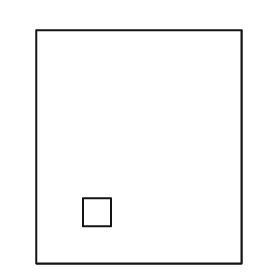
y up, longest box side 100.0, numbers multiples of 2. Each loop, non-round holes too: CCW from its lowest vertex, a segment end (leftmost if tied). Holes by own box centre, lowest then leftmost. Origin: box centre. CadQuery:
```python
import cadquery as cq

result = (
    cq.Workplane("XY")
    .moveTo(-44.0, -50.0)
    .lineTo(44.0, -50.0)
    .lineTo(44.0, 50.0)
    .lineTo(-44.0, 50.0)
    .close()
    .moveTo(-24.0, -34.0)
    .lineTo(-12.0, -34.0)
    .lineTo(-12.0, -22.0)
    .lineTo(-24.0, -22.0)
    .close()
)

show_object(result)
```